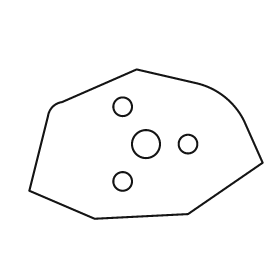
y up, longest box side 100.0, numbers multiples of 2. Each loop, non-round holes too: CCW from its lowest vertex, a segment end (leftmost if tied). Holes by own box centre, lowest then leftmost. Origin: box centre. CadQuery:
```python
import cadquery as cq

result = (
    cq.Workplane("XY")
    .moveTo(-22.0, -32.0)
    .lineTo(18.0, -30.0)
    .lineTo(50.0, -8.0)
    .lineTo(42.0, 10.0)
    .threePointArc((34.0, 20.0), (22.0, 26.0))
    .lineTo(-4.0, 32.0)
    .lineTo(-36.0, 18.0)
    .threePointArc((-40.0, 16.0), (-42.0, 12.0))
    .lineTo(-50.0, -20.0)
    .close()
    .moveTo(-10.0, -16.0)
    .circle(4.0)
    .moveTo(0.0, 0.0)
    .circle(6.0)
    .moveTo(18.0, 0.0)
    .circle(4.0)
    .moveTo(-10.0, 16.0)
    .circle(4.0)
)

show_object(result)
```